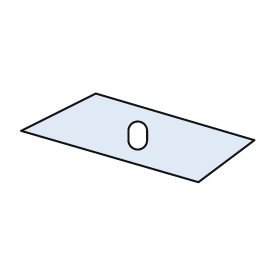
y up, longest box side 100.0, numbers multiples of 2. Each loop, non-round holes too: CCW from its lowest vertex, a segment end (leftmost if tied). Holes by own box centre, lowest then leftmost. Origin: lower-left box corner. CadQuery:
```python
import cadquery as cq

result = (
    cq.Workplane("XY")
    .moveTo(76.0, 0.0)
    .lineTo(100.0, 18.0)
    .lineTo(32.0, 38.0)
    .lineTo(0.0, 22.0)
    .close()
    .moveTo(46.0, 18.0)
    .threePointArc((50.0, 14.0), (54.0, 18.0))
    .lineTo(54.0, 22.0)
    .threePointArc((50.0, 26.0), (46.0, 22.0))
    .close()
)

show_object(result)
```